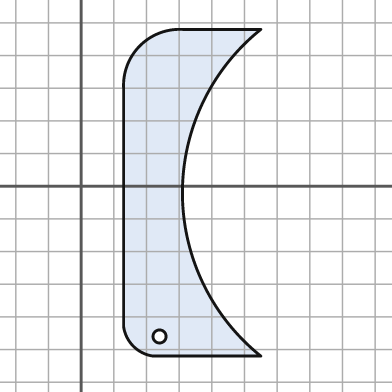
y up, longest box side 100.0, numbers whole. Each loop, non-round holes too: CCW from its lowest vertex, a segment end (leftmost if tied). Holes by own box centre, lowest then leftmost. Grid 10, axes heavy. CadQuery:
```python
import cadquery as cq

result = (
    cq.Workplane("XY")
    .moveTo(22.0, -52.0)
    .lineTo(55.0, -52.0)
    .threePointArc((31.0, -2.0), (55.0, 48.0))
    .lineTo(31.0, 48.0)
    .threePointArc((18.0, 43.0), (13.0, 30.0))
    .lineTo(13.0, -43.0)
    .threePointArc((16.0, -49.0), (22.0, -52.0))
    .close()
    .moveTo(24.0, -46.0)
    .circle(2.0)
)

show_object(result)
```